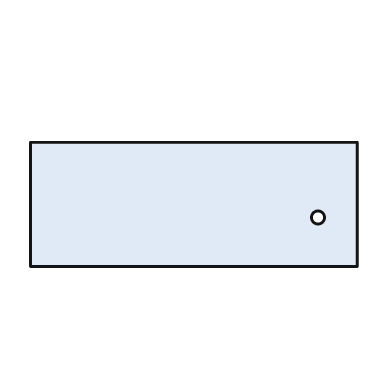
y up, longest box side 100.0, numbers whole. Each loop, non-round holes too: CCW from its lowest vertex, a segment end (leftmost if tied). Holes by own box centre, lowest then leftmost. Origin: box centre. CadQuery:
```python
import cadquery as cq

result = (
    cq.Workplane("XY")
    .moveTo(-50.0, -19.0)
    .lineTo(50.0, -19.0)
    .lineTo(50.0, 19.0)
    .lineTo(-50.0, 19.0)
    .close()
    .moveTo(38.0, -4.0)
    .circle(2.0)
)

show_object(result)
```